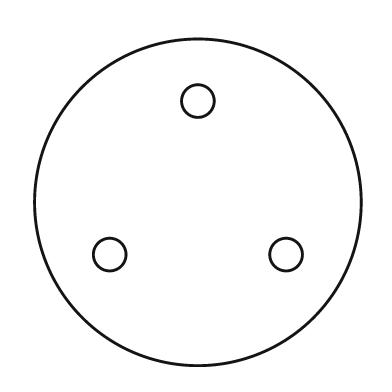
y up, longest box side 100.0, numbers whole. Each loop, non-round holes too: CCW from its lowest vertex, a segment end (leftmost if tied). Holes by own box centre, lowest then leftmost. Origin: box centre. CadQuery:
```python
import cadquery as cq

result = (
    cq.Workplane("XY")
    .moveTo(0.0, 0.0)
    .circle(50.0)
    .moveTo(-27.0, -16.0)
    .circle(5.0)
    .moveTo(27.0, -16.0)
    .circle(5.0)
    .moveTo(0.0, 31.0)
    .circle(5.0)
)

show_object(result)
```